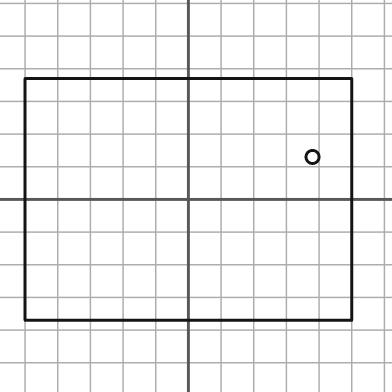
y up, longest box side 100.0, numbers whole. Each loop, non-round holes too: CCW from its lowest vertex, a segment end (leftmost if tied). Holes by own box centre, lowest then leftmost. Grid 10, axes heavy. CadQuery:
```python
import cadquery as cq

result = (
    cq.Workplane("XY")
    .moveTo(-50.0, -37.0)
    .lineTo(50.0, -37.0)
    .lineTo(50.0, 37.0)
    .lineTo(-50.0, 37.0)
    .close()
    .moveTo(38.0, 13.0)
    .circle(2.0)
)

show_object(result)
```